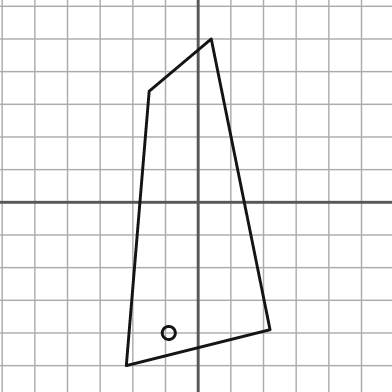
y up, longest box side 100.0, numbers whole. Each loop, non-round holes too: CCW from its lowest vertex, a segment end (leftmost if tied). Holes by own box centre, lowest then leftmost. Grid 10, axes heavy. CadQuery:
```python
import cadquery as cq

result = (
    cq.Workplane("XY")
    .moveTo(-22.0, -50.0)
    .lineTo(22.0, -39.0)
    .lineTo(4.0, 50.0)
    .lineTo(-15.0, 34.0)
    .close()
    .moveTo(-9.0, -40.0)
    .circle(2.0)
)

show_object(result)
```